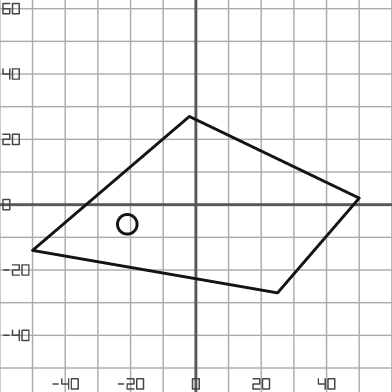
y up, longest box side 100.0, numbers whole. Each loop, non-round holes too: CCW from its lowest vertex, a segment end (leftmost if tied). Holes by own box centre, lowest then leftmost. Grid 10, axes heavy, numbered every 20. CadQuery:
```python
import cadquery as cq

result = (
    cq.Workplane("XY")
    .moveTo(25.0, -27.0)
    .lineTo(50.0, 2.0)
    .lineTo(-2.0, 27.0)
    .lineTo(-50.0, -14.0)
    .close()
    .moveTo(-21.0, -6.0)
    .circle(3.0)
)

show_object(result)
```